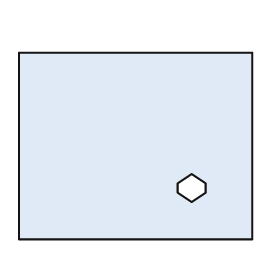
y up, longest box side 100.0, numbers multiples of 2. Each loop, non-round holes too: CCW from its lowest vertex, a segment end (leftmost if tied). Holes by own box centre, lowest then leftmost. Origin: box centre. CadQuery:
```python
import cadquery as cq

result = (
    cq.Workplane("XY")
    .moveTo(-50.0, -40.0)
    .lineTo(50.0, -40.0)
    .lineTo(50.0, 40.0)
    .lineTo(-50.0, 40.0)
    .close()
    .moveTo(24.0, -24.0)
    .lineTo(30.0, -20.0)
    .lineTo(30.0, -16.0)
    .lineTo(24.0, -12.0)
    .lineTo(18.0, -16.0)
    .lineTo(18.0, -20.0)
    .close()
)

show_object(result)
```